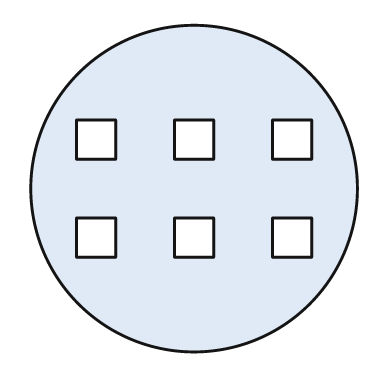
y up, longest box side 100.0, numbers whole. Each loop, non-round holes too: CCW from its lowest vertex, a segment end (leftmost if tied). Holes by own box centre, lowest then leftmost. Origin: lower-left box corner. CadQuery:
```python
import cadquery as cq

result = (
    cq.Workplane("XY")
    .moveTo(50.0, 50.0)
    .circle(50.0)
    .moveTo(14.0, 29.0)
    .lineTo(26.0, 29.0)
    .lineTo(26.0, 41.0)
    .lineTo(14.0, 41.0)
    .close()
    .moveTo(44.0, 29.0)
    .lineTo(56.0, 29.0)
    .lineTo(56.0, 41.0)
    .lineTo(44.0, 41.0)
    .close()
    .moveTo(74.0, 29.0)
    .lineTo(86.0, 29.0)
    .lineTo(86.0, 41.0)
    .lineTo(74.0, 41.0)
    .close()
    .moveTo(14.0, 59.0)
    .lineTo(26.0, 59.0)
    .lineTo(26.0, 71.0)
    .lineTo(14.0, 71.0)
    .close()
    .moveTo(44.0, 59.0)
    .lineTo(56.0, 59.0)
    .lineTo(56.0, 71.0)
    .lineTo(44.0, 71.0)
    .close()
    .moveTo(74.0, 59.0)
    .lineTo(86.0, 59.0)
    .lineTo(86.0, 71.0)
    .lineTo(74.0, 71.0)
    .close()
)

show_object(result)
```